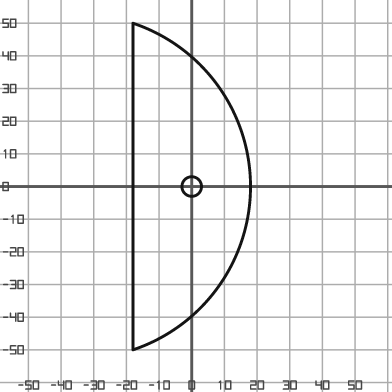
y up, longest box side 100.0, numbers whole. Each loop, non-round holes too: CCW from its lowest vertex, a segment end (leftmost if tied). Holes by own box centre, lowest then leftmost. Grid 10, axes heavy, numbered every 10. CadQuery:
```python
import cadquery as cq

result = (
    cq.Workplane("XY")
    .moveTo(-18.0, -50.0)
    .threePointArc((18.0, 0.0), (-18.0, 50.0))
    .close()
    .moveTo(0.0, 0.0)
    .circle(3.0)
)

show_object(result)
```